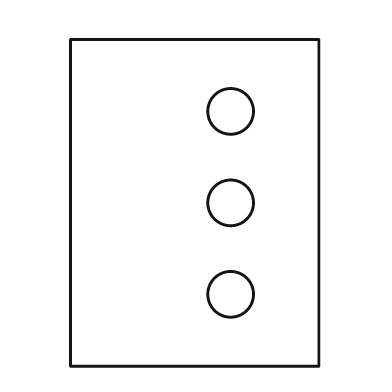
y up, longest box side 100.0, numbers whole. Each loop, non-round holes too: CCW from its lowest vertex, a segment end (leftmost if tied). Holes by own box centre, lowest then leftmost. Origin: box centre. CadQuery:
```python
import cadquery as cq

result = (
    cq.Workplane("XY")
    .moveTo(-38.0, -50.0)
    .lineTo(38.0, -50.0)
    .lineTo(38.0, 50.0)
    .lineTo(-38.0, 50.0)
    .close()
    .moveTo(11.0, -28.0)
    .circle(7.0)
    .moveTo(11.0, 0.0)
    .circle(7.0)
    .moveTo(11.0, 28.0)
    .circle(7.0)
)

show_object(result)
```